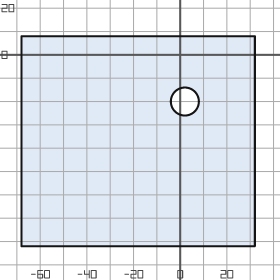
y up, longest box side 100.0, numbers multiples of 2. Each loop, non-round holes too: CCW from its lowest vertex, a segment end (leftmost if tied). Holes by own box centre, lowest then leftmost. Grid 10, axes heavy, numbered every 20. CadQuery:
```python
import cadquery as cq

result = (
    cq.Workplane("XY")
    .moveTo(-68.0, -82.0)
    .lineTo(32.0, -82.0)
    .lineTo(32.0, 8.0)
    .lineTo(-68.0, 8.0)
    .close()
    .moveTo(2.0, -20.0)
    .circle(6.0)
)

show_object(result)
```